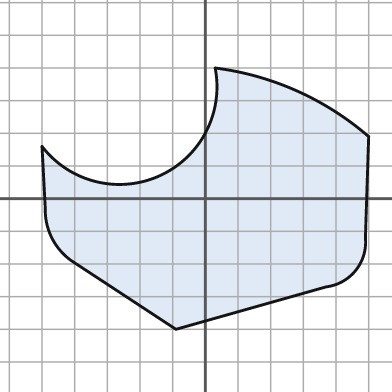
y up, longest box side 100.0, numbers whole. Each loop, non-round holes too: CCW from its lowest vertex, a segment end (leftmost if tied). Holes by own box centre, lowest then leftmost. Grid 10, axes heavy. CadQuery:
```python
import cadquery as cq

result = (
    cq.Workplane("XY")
    .moveTo(-9.0, -40.0)
    .lineTo(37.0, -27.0)
    .threePointArc((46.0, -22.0), (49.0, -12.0))
    .lineTo(50.0, 19.0)
    .threePointArc((28.0, 33.0), (3.0, 40.0))
    .threePointArc((-14.0, 7.0), (-50.0, 16.0))
    .lineTo(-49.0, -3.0)
    .threePointArc((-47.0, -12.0), (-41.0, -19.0))
    .close()
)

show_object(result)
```